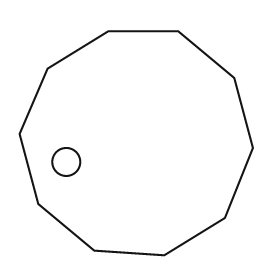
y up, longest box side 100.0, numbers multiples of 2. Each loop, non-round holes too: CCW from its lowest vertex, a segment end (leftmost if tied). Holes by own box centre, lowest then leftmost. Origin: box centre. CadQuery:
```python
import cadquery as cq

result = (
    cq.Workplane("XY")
    .moveTo(12.0, -48.0)
    .lineTo(38.0, -32.0)
    .lineTo(50.0, -2.0)
    .lineTo(42.0, 28.0)
    .lineTo(18.0, 48.0)
    .lineTo(-12.0, 48.0)
    .lineTo(-38.0, 32.0)
    .lineTo(-50.0, 4.0)
    .lineTo(-42.0, -26.0)
    .lineTo(-18.0, -46.0)
    .close()
    .moveTo(-30.0, -8.0)
    .circle(6.0)
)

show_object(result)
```